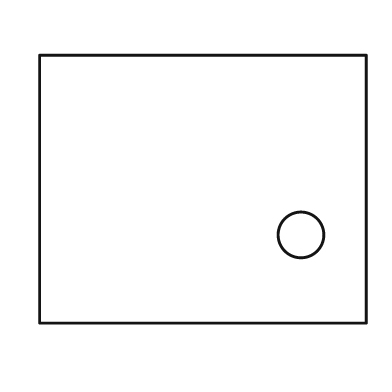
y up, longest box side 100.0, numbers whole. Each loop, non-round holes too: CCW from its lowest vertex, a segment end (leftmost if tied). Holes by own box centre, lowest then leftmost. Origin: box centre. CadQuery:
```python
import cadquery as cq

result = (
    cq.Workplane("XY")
    .moveTo(-50.0, -41.0)
    .lineTo(50.0, -41.0)
    .lineTo(50.0, 41.0)
    .lineTo(-50.0, 41.0)
    .close()
    .moveTo(30.0, -14.0)
    .circle(7.0)
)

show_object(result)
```